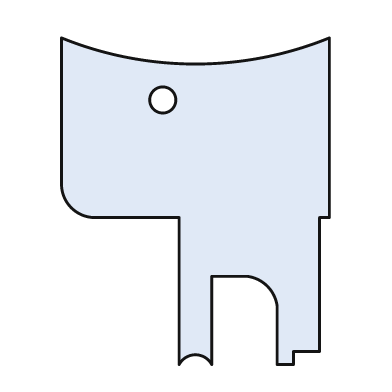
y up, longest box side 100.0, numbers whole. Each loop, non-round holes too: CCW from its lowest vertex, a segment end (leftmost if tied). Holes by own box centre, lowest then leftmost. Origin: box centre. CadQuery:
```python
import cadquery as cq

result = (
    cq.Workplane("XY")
    .moveTo(-5.0, -50.0)
    .threePointArc((0.0, -47.0), (5.0, -50.0))
    .lineTo(5.0, -23.0)
    .lineTo(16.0, -23.0)
    .threePointArc((22.0, -26.0), (25.0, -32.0))
    .lineTo(25.0, -50.0)
    .lineTo(30.0, -50.0)
    .lineTo(30.0, -46.0)
    .lineTo(38.0, -46.0)
    .lineTo(38.0, -5.0)
    .lineTo(41.0, -5.0)
    .lineTo(41.0, 50.0)
    .threePointArc((0.0, 42.0), (-41.0, 50.0))
    .lineTo(-41.0, 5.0)
    .threePointArc((-38.0, -2.0), (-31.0, -5.0))
    .lineTo(-5.0, -5.0)
    .close()
    .moveTo(-10.0, 31.0)
    .circle(4.0)
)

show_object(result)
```